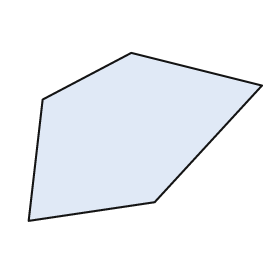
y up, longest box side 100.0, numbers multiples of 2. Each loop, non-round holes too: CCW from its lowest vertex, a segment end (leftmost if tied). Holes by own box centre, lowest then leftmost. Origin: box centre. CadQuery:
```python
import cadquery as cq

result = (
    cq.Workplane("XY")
    .moveTo(-50.0, -36.0)
    .lineTo(4.0, -28.0)
    .lineTo(50.0, 22.0)
    .lineTo(-6.0, 36.0)
    .lineTo(-44.0, 16.0)
    .close()
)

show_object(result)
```